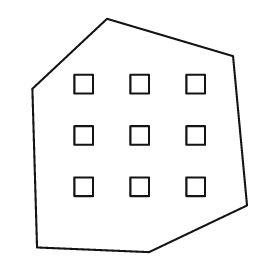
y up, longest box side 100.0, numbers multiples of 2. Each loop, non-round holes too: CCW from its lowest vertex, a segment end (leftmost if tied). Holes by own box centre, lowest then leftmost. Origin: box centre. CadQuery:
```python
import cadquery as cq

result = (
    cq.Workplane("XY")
    .moveTo(4.0, -50.0)
    .lineTo(46.0, -30.0)
    .lineTo(40.0, 34.0)
    .lineTo(-14.0, 50.0)
    .lineTo(-46.0, 20.0)
    .lineTo(-44.0, -48.0)
    .close()
    .moveTo(-28.0, -26.0)
    .lineTo(-20.0, -26.0)
    .lineTo(-20.0, -18.0)
    .lineTo(-28.0, -18.0)
    .close()
    .moveTo(-4.0, -26.0)
    .lineTo(4.0, -26.0)
    .lineTo(4.0, -18.0)
    .lineTo(-4.0, -18.0)
    .close()
    .moveTo(20.0, -26.0)
    .lineTo(28.0, -26.0)
    .lineTo(28.0, -18.0)
    .lineTo(20.0, -18.0)
    .close()
    .moveTo(-28.0, -4.0)
    .lineTo(-20.0, -4.0)
    .lineTo(-20.0, 4.0)
    .lineTo(-28.0, 4.0)
    .close()
    .moveTo(-4.0, -4.0)
    .lineTo(4.0, -4.0)
    .lineTo(4.0, 4.0)
    .lineTo(-4.0, 4.0)
    .close()
    .moveTo(20.0, -4.0)
    .lineTo(28.0, -4.0)
    .lineTo(28.0, 4.0)
    .lineTo(20.0, 4.0)
    .close()
    .moveTo(-28.0, 18.0)
    .lineTo(-20.0, 18.0)
    .lineTo(-20.0, 26.0)
    .lineTo(-28.0, 26.0)
    .close()
    .moveTo(-4.0, 18.0)
    .lineTo(4.0, 18.0)
    .lineTo(4.0, 26.0)
    .lineTo(-4.0, 26.0)
    .close()
    .moveTo(20.0, 18.0)
    .lineTo(28.0, 18.0)
    .lineTo(28.0, 26.0)
    .lineTo(20.0, 26.0)
    .close()
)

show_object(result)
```